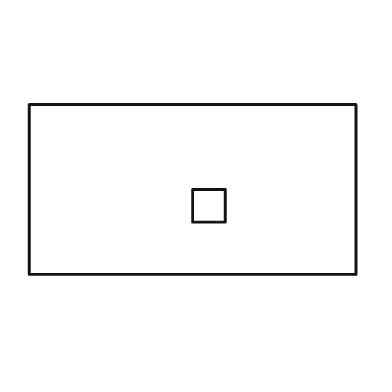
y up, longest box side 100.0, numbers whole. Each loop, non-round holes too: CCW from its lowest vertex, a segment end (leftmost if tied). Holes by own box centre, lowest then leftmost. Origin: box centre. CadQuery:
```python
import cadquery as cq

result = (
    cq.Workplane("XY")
    .moveTo(-50.0, -26.0)
    .lineTo(50.0, -26.0)
    .lineTo(50.0, 26.0)
    .lineTo(-50.0, 26.0)
    .close()
    .moveTo(0.0, -10.0)
    .lineTo(10.0, -10.0)
    .lineTo(10.0, 0.0)
    .lineTo(0.0, 0.0)
    .close()
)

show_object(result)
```